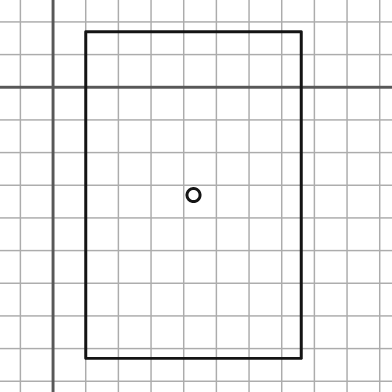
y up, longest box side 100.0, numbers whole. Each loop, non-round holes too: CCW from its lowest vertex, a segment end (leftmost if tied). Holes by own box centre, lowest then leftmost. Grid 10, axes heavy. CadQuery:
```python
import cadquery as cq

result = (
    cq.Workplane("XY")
    .moveTo(10.0, -83.0)
    .lineTo(76.0, -83.0)
    .lineTo(76.0, 17.0)
    .lineTo(10.0, 17.0)
    .close()
    .moveTo(43.0, -33.0)
    .circle(2.0)
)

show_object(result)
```